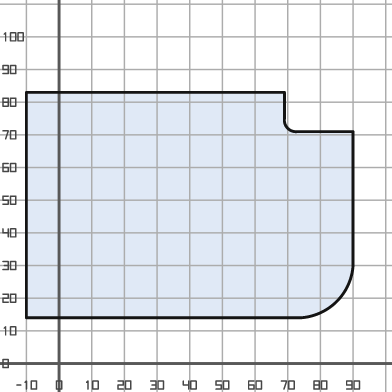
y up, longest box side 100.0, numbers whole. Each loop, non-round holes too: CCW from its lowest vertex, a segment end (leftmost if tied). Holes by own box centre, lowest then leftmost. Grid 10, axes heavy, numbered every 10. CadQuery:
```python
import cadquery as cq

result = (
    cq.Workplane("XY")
    .moveTo(-10.0, 14.0)
    .lineTo(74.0, 14.0)
    .threePointArc((85.0, 19.0), (90.0, 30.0))
    .lineTo(90.0, 71.0)
    .lineTo(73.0, 71.0)
    .threePointArc((70.0, 72.0), (69.0, 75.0))
    .lineTo(69.0, 83.0)
    .lineTo(-10.0, 83.0)
    .close()
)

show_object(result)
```